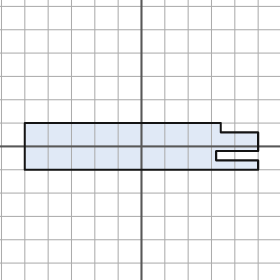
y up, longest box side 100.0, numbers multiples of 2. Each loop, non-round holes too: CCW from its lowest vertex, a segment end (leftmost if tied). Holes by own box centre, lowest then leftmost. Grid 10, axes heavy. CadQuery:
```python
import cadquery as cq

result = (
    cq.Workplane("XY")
    .moveTo(-50.0, -10.0)
    .lineTo(50.0, -10.0)
    .lineTo(50.0, -6.0)
    .lineTo(32.0, -6.0)
    .lineTo(32.0, -2.0)
    .lineTo(50.0, -2.0)
    .lineTo(50.0, 6.0)
    .lineTo(34.0, 6.0)
    .lineTo(34.0, 10.0)
    .lineTo(-50.0, 10.0)
    .close()
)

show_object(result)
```